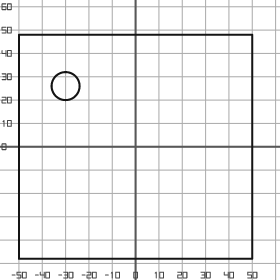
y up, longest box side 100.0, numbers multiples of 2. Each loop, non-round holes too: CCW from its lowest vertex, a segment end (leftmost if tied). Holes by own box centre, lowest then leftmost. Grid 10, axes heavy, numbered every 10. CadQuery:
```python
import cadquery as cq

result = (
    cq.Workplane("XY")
    .moveTo(-50.0, -48.0)
    .lineTo(50.0, -48.0)
    .lineTo(50.0, 48.0)
    .lineTo(-50.0, 48.0)
    .close()
    .moveTo(-30.0, 26.0)
    .circle(6.0)
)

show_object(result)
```